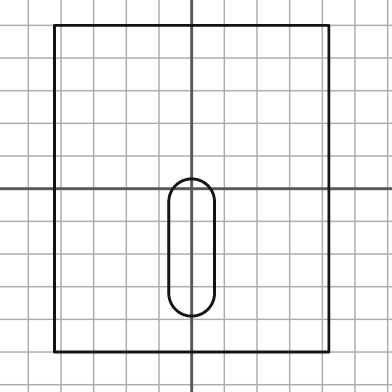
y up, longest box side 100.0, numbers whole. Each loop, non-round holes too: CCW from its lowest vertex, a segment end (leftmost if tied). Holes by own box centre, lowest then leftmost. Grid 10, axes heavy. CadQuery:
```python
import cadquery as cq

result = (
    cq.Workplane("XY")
    .moveTo(-42.0, -50.0)
    .lineTo(42.0, -50.0)
    .lineTo(42.0, 50.0)
    .lineTo(-42.0, 50.0)
    .close()
    .moveTo(-7.0, -32.0)
    .threePointArc((0.0, -39.0), (7.0, -32.0))
    .lineTo(7.0, -4.0)
    .threePointArc((0.0, 3.0), (-7.0, -4.0))
    .close()
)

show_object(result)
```